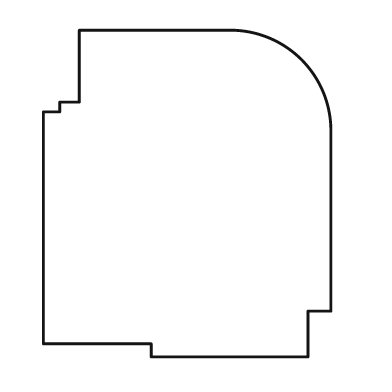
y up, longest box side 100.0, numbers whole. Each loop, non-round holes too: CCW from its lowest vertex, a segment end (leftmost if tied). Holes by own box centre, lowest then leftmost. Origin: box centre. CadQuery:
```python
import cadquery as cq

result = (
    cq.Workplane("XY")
    .moveTo(-11.0, -50.0)
    .lineTo(37.0, -50.0)
    .lineTo(37.0, -36.0)
    .lineTo(44.0, -36.0)
    .lineTo(44.0, 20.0)
    .threePointArc((35.0, 41.0), (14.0, 50.0))
    .lineTo(-33.0, 50.0)
    .lineTo(-33.0, 28.0)
    .lineTo(-39.0, 28.0)
    .lineTo(-39.0, 25.0)
    .lineTo(-44.0, 25.0)
    .lineTo(-44.0, -46.0)
    .lineTo(-11.0, -46.0)
    .close()
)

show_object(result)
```